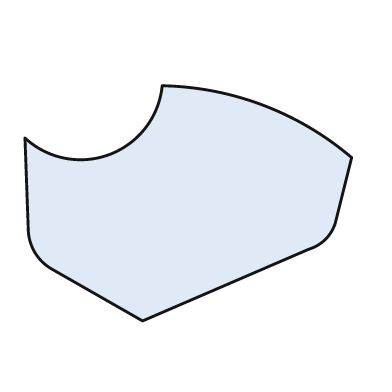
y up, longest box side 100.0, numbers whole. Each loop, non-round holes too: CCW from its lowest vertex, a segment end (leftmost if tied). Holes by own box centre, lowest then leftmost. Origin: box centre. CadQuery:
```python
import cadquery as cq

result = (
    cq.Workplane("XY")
    .moveTo(-14.0, -36.0)
    .lineTo(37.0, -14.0)
    .threePointArc((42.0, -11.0), (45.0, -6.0))
    .lineTo(50.0, 14.0)
    .threePointArc((23.0, 30.0), (-8.0, 36.0))
    .threePointArc((-24.0, 15.0), (-50.0, 20.0))
    .lineTo(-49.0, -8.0)
    .threePointArc((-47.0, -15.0), (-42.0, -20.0))
    .close()
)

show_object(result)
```